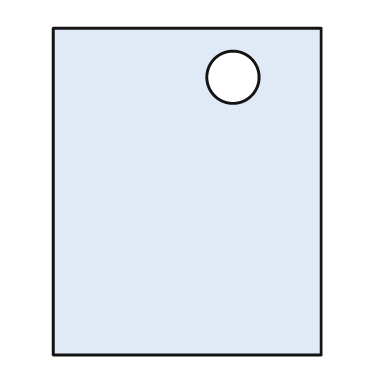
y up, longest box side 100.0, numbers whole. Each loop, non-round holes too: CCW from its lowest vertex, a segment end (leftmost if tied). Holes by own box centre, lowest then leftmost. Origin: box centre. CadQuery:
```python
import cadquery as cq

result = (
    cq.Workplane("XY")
    .moveTo(-41.0, -50.0)
    .lineTo(41.0, -50.0)
    .lineTo(41.0, 50.0)
    .lineTo(-41.0, 50.0)
    .close()
    .moveTo(14.0, 35.0)
    .circle(8.0)
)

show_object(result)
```